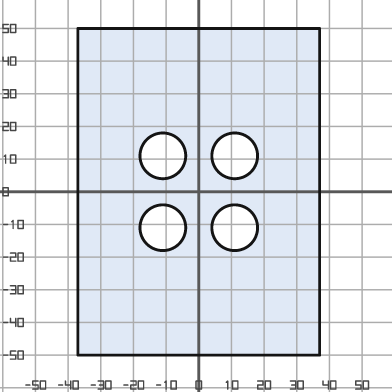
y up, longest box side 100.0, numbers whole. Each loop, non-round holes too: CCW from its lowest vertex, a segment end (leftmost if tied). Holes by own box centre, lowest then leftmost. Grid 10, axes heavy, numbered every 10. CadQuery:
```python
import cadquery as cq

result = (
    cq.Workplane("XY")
    .moveTo(-37.0, -50.0)
    .lineTo(37.0, -50.0)
    .lineTo(37.0, 50.0)
    .lineTo(-37.0, 50.0)
    .close()
    .moveTo(-11.0, -11.0)
    .circle(7.0)
    .moveTo(11.0, -11.0)
    .circle(7.0)
    .moveTo(-11.0, 11.0)
    .circle(7.0)
    .moveTo(11.0, 11.0)
    .circle(7.0)
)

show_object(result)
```